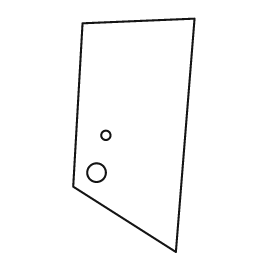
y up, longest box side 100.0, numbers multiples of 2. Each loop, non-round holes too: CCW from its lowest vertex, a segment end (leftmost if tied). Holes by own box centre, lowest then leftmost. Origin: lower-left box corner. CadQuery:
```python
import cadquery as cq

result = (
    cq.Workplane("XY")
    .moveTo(44.0, 0.0)
    .lineTo(52.0, 100.0)
    .lineTo(4.0, 98.0)
    .lineTo(0.0, 28.0)
    .close()
    .moveTo(10.0, 34.0)
    .circle(4.0)
    .moveTo(14.0, 50.0)
    .circle(2.0)
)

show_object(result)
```